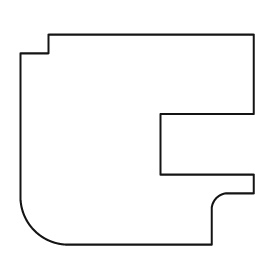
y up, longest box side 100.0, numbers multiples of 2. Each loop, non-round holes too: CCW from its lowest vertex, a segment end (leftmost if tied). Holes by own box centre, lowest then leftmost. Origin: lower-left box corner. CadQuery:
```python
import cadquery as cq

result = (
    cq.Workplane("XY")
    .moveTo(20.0, 0.0)
    .lineTo(82.0, 0.0)
    .lineTo(82.0, 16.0)
    .threePointArc((84.0, 20.0), (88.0, 22.0))
    .lineTo(100.0, 22.0)
    .lineTo(100.0, 30.0)
    .lineTo(60.0, 30.0)
    .lineTo(60.0, 56.0)
    .lineTo(100.0, 56.0)
    .lineTo(100.0, 90.0)
    .lineTo(12.0, 90.0)
    .lineTo(12.0, 82.0)
    .lineTo(0.0, 82.0)
    .lineTo(0.0, 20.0)
    .threePointArc((6.0, 6.0), (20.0, 0.0))
    .close()
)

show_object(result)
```